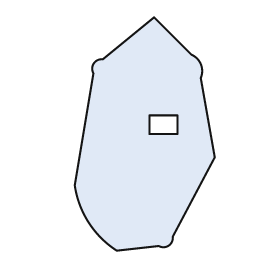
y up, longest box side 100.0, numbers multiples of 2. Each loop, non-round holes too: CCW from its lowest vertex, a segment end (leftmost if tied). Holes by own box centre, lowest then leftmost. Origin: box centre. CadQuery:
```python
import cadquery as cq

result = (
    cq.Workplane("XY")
    .moveTo(-12.0, -50.0)
    .lineTo(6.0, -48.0)
    .threePointArc((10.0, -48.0), (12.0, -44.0))
    .lineTo(30.0, -10.0)
    .lineTo(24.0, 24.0)
    .threePointArc((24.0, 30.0), (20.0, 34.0))
    .lineTo(4.0, 50.0)
    .lineTo(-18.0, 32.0)
    .threePointArc((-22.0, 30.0), (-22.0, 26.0))
    .lineTo(-30.0, -22.0)
    .threePointArc((-24.0, -38.0), (-12.0, -50.0))
    .close()
    .moveTo(2.0, 0.0)
    .lineTo(14.0, 0.0)
    .lineTo(14.0, 8.0)
    .lineTo(2.0, 8.0)
    .close()
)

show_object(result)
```